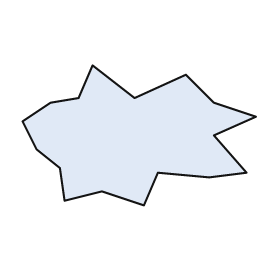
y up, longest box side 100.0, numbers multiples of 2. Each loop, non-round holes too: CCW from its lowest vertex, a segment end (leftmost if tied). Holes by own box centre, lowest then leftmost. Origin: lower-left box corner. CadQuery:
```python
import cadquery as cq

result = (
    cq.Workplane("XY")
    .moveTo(52.0, 0.0)
    .lineTo(58.0, 14.0)
    .lineTo(80.0, 12.0)
    .lineTo(96.0, 14.0)
    .lineTo(82.0, 30.0)
    .lineTo(100.0, 38.0)
    .lineTo(82.0, 44.0)
    .lineTo(70.0, 56.0)
    .lineTo(48.0, 46.0)
    .lineTo(30.0, 60.0)
    .lineTo(24.0, 46.0)
    .lineTo(12.0, 44.0)
    .lineTo(0.0, 36.0)
    .lineTo(6.0, 24.0)
    .lineTo(16.0, 16.0)
    .lineTo(18.0, 2.0)
    .lineTo(34.0, 6.0)
    .close()
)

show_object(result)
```